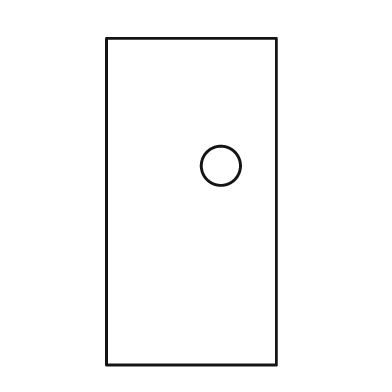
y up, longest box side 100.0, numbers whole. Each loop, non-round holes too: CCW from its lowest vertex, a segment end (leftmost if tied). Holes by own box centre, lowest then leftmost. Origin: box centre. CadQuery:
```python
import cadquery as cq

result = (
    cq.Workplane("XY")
    .moveTo(-26.0, -50.0)
    .lineTo(26.0, -50.0)
    .lineTo(26.0, 50.0)
    .lineTo(-26.0, 50.0)
    .close()
    .moveTo(9.0, 11.0)
    .circle(6.0)
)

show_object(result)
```